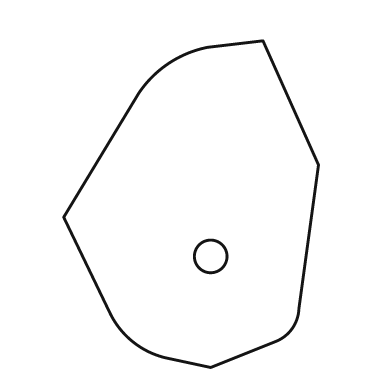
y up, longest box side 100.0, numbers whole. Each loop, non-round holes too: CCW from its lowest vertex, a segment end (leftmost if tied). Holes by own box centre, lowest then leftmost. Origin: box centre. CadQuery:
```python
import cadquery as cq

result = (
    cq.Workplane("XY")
    .moveTo(6.0, -50.0)
    .lineTo(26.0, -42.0)
    .threePointArc((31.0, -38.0), (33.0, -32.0))
    .lineTo(39.0, 12.0)
    .lineTo(22.0, 50.0)
    .lineTo(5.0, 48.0)
    .threePointArc((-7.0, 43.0), (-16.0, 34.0))
    .lineTo(-39.0, -4.0)
    .lineTo(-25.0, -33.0)
    .threePointArc((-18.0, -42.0), (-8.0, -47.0))
    .close()
    .moveTo(6.0, -16.0)
    .circle(5.0)
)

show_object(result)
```